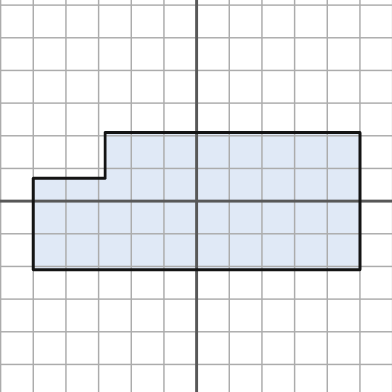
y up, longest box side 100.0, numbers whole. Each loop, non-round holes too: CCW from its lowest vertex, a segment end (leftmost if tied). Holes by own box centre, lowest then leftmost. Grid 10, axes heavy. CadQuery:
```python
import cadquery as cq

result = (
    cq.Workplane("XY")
    .moveTo(-50.0, -21.0)
    .lineTo(50.0, -21.0)
    .lineTo(50.0, 21.0)
    .lineTo(-28.0, 21.0)
    .lineTo(-28.0, 7.0)
    .lineTo(-50.0, 7.0)
    .close()
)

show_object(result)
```